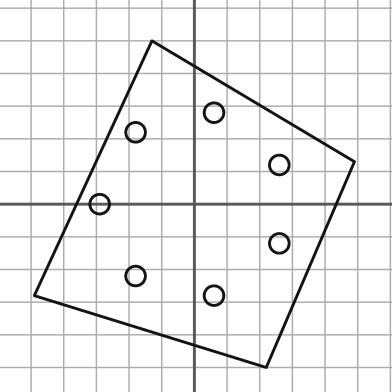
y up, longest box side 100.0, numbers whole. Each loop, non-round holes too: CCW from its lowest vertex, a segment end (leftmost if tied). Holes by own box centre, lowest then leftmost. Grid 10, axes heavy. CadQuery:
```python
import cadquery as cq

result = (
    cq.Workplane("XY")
    .moveTo(22.0, -50.0)
    .lineTo(49.0, 13.0)
    .lineTo(-13.0, 50.0)
    .lineTo(-49.0, -28.0)
    .close()
    .moveTo(6.0, -28.0)
    .circle(3.0)
    .moveTo(-18.0, -22.0)
    .circle(3.0)
    .moveTo(26.0, -12.0)
    .circle(3.0)
    .moveTo(-29.0, 0.0)
    .circle(3.0)
    .moveTo(26.0, 12.0)
    .circle(3.0)
    .moveTo(-18.0, 22.0)
    .circle(3.0)
    .moveTo(6.0, 28.0)
    .circle(3.0)
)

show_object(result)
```